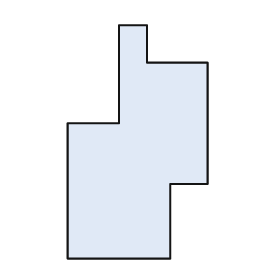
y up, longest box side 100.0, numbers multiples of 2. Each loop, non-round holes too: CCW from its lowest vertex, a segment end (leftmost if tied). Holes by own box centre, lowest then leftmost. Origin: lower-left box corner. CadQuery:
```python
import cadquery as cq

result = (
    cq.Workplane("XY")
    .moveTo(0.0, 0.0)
    .lineTo(44.0, 0.0)
    .lineTo(44.0, 32.0)
    .lineTo(60.0, 32.0)
    .lineTo(60.0, 84.0)
    .lineTo(34.0, 84.0)
    .lineTo(34.0, 100.0)
    .lineTo(22.0, 100.0)
    .lineTo(22.0, 58.0)
    .lineTo(0.0, 58.0)
    .close()
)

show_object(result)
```